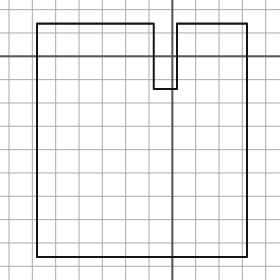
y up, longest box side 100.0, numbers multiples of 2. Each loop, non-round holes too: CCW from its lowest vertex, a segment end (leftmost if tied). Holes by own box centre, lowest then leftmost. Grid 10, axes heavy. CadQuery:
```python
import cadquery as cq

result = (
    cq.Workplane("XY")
    .moveTo(-58.0, -86.0)
    .lineTo(32.0, -86.0)
    .lineTo(32.0, 14.0)
    .lineTo(2.0, 14.0)
    .lineTo(2.0, -14.0)
    .lineTo(-8.0, -14.0)
    .lineTo(-8.0, 14.0)
    .lineTo(-58.0, 14.0)
    .close()
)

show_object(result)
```